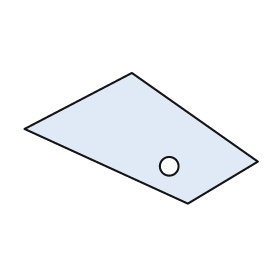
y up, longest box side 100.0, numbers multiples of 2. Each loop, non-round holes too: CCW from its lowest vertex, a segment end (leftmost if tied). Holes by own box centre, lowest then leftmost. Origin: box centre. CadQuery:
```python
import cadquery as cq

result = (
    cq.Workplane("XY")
    .moveTo(20.0, -28.0)
    .lineTo(50.0, -10.0)
    .lineTo(-4.0, 28.0)
    .lineTo(-50.0, 4.0)
    .close()
    .moveTo(12.0, -12.0)
    .circle(4.0)
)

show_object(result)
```